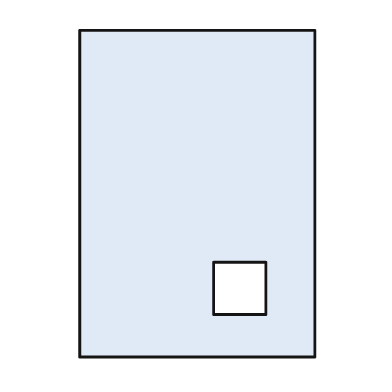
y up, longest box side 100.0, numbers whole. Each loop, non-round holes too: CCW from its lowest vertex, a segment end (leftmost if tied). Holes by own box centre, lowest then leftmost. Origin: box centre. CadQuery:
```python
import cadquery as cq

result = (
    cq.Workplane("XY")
    .moveTo(-36.0, -50.0)
    .lineTo(36.0, -50.0)
    .lineTo(36.0, 50.0)
    .lineTo(-36.0, 50.0)
    .close()
    .moveTo(5.0, -37.0)
    .lineTo(21.0, -37.0)
    .lineTo(21.0, -21.0)
    .lineTo(5.0, -21.0)
    .close()
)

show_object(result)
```